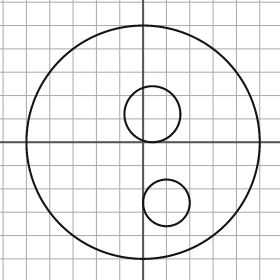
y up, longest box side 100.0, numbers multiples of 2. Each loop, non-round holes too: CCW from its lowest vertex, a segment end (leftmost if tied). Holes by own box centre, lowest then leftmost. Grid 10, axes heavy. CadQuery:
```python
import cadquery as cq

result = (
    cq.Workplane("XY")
    .moveTo(0.0, 0.0)
    .circle(50.0)
    .moveTo(10.0, -26.0)
    .circle(10.0)
    .moveTo(4.0, 12.0)
    .circle(12.0)
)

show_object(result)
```